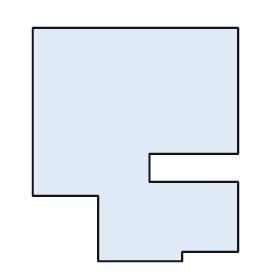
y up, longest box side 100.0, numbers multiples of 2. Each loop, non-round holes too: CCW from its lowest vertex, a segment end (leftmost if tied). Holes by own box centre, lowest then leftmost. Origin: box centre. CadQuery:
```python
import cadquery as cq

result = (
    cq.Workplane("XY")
    .moveTo(-16.0, -50.0)
    .lineTo(20.0, -50.0)
    .lineTo(20.0, -46.0)
    .lineTo(44.0, -46.0)
    .lineTo(44.0, -16.0)
    .lineTo(6.0, -16.0)
    .lineTo(6.0, -4.0)
    .lineTo(44.0, -4.0)
    .lineTo(44.0, 50.0)
    .lineTo(-44.0, 50.0)
    .lineTo(-44.0, -22.0)
    .lineTo(-16.0, -22.0)
    .close()
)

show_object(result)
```